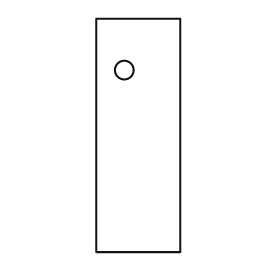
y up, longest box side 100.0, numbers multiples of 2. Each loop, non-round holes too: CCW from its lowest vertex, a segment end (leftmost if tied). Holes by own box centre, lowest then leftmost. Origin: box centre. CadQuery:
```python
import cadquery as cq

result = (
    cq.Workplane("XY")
    .moveTo(-18.0, -50.0)
    .lineTo(18.0, -50.0)
    .lineTo(18.0, 50.0)
    .lineTo(-18.0, 50.0)
    .close()
    .moveTo(-6.0, 28.0)
    .circle(4.0)
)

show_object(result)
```